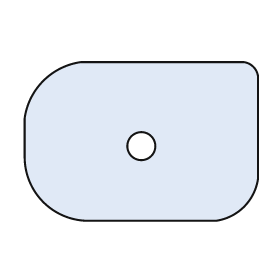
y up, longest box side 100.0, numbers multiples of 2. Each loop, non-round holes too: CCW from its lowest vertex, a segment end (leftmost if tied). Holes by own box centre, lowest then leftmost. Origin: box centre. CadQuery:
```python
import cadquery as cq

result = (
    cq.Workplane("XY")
    .moveTo(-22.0, -34.0)
    .lineTo(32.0, -34.0)
    .threePointArc((44.0, -28.0), (50.0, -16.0))
    .lineTo(50.0, 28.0)
    .threePointArc((48.0, 32.0), (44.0, 34.0))
    .lineTo(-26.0, 34.0)
    .threePointArc((-42.0, 26.0), (-50.0, 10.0))
    .lineTo(-50.0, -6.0)
    .threePointArc((-42.0, -26.0), (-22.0, -34.0))
    .close()
    .moveTo(0.0, -2.0)
    .circle(6.0)
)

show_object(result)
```